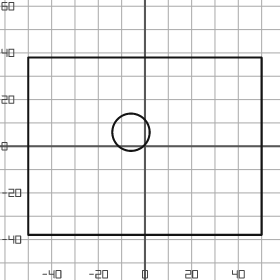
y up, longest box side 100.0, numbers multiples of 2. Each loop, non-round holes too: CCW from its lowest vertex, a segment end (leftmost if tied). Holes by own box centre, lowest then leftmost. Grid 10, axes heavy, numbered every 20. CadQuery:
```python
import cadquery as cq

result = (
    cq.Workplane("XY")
    .moveTo(-50.0, -38.0)
    .lineTo(50.0, -38.0)
    .lineTo(50.0, 38.0)
    .lineTo(-50.0, 38.0)
    .close()
    .moveTo(-6.0, 6.0)
    .circle(8.0)
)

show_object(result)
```